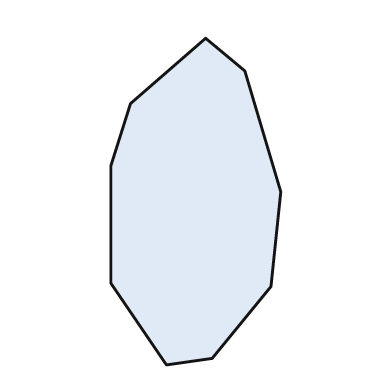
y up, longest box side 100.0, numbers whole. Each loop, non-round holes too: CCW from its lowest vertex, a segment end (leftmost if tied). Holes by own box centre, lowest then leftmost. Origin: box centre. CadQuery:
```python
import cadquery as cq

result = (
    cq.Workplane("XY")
    .moveTo(-9.0, -50.0)
    .lineTo(5.0, -48.0)
    .lineTo(23.0, -26.0)
    .lineTo(26.0, 3.0)
    .lineTo(15.0, 40.0)
    .lineTo(3.0, 50.0)
    .lineTo(-20.0, 30.0)
    .lineTo(-26.0, 11.0)
    .lineTo(-26.0, -25.0)
    .close()
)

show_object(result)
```